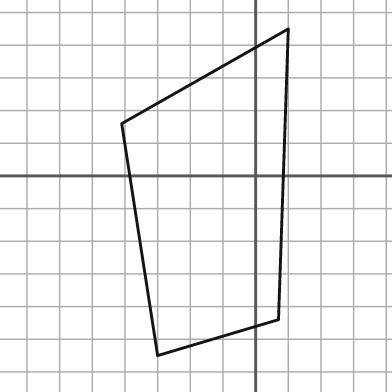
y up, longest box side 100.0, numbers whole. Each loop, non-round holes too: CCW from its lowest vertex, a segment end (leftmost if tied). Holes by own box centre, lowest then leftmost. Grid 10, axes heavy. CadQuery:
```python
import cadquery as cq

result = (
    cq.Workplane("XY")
    .moveTo(-30.0, -55.0)
    .lineTo(7.0, -44.0)
    .lineTo(10.0, 45.0)
    .lineTo(-41.0, 16.0)
    .close()
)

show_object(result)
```